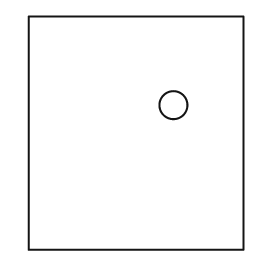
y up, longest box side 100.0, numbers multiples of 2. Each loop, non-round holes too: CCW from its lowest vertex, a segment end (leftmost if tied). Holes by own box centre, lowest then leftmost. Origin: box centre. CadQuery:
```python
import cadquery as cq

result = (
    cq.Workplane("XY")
    .moveTo(-46.0, -50.0)
    .lineTo(46.0, -50.0)
    .lineTo(46.0, 50.0)
    .lineTo(-46.0, 50.0)
    .close()
    .moveTo(16.0, 12.0)
    .circle(6.0)
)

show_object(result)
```